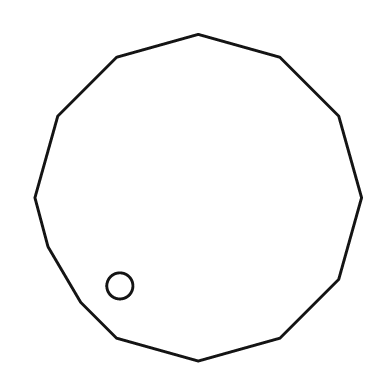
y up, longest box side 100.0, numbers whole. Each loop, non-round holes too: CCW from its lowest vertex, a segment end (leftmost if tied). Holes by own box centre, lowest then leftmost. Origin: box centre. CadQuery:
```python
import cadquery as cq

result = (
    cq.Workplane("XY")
    .moveTo(0.0, -50.0)
    .lineTo(25.0, -43.0)
    .lineTo(43.0, -25.0)
    .lineTo(50.0, 0.0)
    .lineTo(43.0, 25.0)
    .lineTo(25.0, 43.0)
    .lineTo(0.0, 50.0)
    .lineTo(-25.0, 43.0)
    .lineTo(-43.0, 25.0)
    .lineTo(-50.0, 0.0)
    .lineTo(-46.0, -15.0)
    .lineTo(-36.0, -32.0)
    .lineTo(-25.0, -43.0)
    .close()
    .moveTo(-24.0, -27.0)
    .circle(4.0)
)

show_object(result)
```